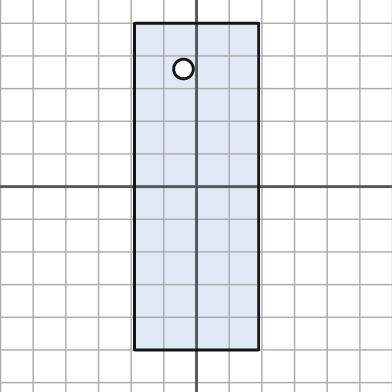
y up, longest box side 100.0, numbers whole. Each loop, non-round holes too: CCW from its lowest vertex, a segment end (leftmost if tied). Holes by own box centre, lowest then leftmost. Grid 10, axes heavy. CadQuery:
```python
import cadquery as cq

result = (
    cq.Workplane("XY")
    .moveTo(-19.0, -50.0)
    .lineTo(19.0, -50.0)
    .lineTo(19.0, 50.0)
    .lineTo(-19.0, 50.0)
    .close()
    .moveTo(-4.0, 36.0)
    .circle(3.0)
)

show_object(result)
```